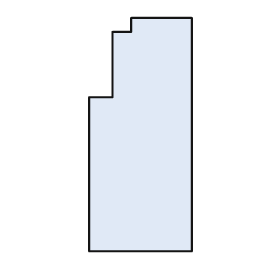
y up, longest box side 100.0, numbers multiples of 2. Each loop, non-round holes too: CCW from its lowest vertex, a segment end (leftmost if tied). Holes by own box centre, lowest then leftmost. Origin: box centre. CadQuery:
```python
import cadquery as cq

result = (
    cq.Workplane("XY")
    .moveTo(-22.0, -50.0)
    .lineTo(22.0, -50.0)
    .lineTo(22.0, 50.0)
    .lineTo(-4.0, 50.0)
    .lineTo(-4.0, 44.0)
    .lineTo(-12.0, 44.0)
    .lineTo(-12.0, 16.0)
    .lineTo(-22.0, 16.0)
    .close()
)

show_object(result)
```